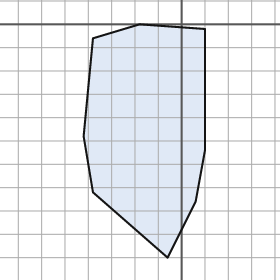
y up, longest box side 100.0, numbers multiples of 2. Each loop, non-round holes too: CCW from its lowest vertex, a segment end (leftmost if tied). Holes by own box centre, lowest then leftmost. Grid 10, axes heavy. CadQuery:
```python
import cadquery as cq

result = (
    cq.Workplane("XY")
    .moveTo(-6.0, -100.0)
    .lineTo(6.0, -76.0)
    .lineTo(10.0, -54.0)
    .lineTo(10.0, -2.0)
    .lineTo(-18.0, 0.0)
    .lineTo(-38.0, -6.0)
    .lineTo(-42.0, -48.0)
    .lineTo(-38.0, -72.0)
    .close()
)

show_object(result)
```